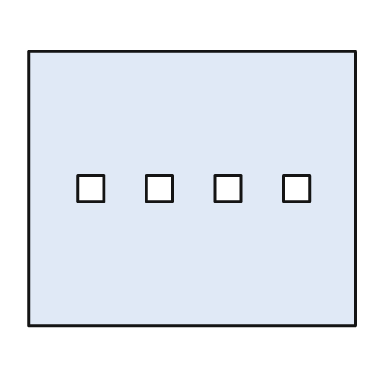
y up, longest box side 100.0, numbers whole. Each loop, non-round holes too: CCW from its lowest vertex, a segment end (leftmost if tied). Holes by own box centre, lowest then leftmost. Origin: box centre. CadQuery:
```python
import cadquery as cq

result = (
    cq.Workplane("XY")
    .moveTo(-50.0, -42.0)
    .lineTo(50.0, -42.0)
    .lineTo(50.0, 42.0)
    .lineTo(-50.0, 42.0)
    .close()
    .moveTo(-35.0, -4.0)
    .lineTo(-27.0, -4.0)
    .lineTo(-27.0, 4.0)
    .lineTo(-35.0, 4.0)
    .close()
    .moveTo(-14.0, -4.0)
    .lineTo(-6.0, -4.0)
    .lineTo(-6.0, 4.0)
    .lineTo(-14.0, 4.0)
    .close()
    .moveTo(7.0, -4.0)
    .lineTo(15.0, -4.0)
    .lineTo(15.0, 4.0)
    .lineTo(7.0, 4.0)
    .close()
    .moveTo(28.0, -4.0)
    .lineTo(36.0, -4.0)
    .lineTo(36.0, 4.0)
    .lineTo(28.0, 4.0)
    .close()
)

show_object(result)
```